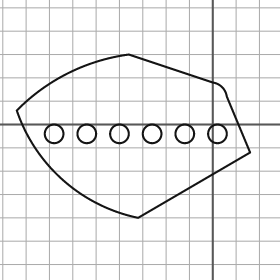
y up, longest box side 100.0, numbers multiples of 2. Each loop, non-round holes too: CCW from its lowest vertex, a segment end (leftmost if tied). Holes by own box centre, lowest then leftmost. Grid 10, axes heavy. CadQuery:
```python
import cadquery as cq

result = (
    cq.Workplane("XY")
    .moveTo(-32.0, -40.0)
    .lineTo(16.0, -12.0)
    .lineTo(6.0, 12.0)
    .threePointArc((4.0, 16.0), (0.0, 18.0))
    .lineTo(-36.0, 30.0)
    .threePointArc((-62.0, 22.0), (-84.0, 6.0))
    .threePointArc((-64.0, -24.0), (-32.0, -40.0))
    .close()
    .moveTo(-68.0, -4.0)
    .circle(4.0)
    .moveTo(-54.0, -4.0)
    .circle(4.0)
    .moveTo(-40.0, -4.0)
    .circle(4.0)
    .moveTo(-26.0, -4.0)
    .circle(4.0)
    .moveTo(-12.0, -4.0)
    .circle(4.0)
    .moveTo(2.0, -4.0)
    .circle(4.0)
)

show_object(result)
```